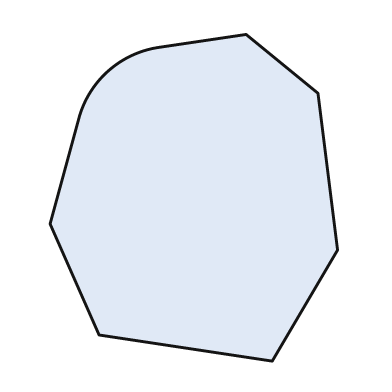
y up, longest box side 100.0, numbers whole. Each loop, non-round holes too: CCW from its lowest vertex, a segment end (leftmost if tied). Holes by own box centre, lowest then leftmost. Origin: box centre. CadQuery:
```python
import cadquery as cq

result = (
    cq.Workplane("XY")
    .moveTo(24.0, -50.0)
    .lineTo(44.0, -16.0)
    .lineTo(38.0, 32.0)
    .lineTo(16.0, 50.0)
    .lineTo(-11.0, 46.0)
    .threePointArc((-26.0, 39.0), (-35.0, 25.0))
    .lineTo(-44.0, -8.0)
    .lineTo(-29.0, -42.0)
    .close()
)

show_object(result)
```